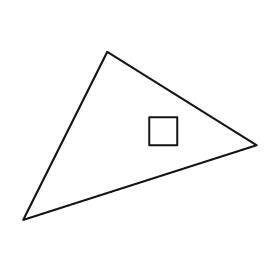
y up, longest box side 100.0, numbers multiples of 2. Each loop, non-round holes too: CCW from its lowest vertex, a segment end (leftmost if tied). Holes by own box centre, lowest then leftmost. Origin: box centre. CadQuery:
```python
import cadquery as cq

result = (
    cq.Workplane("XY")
    .moveTo(-50.0, -36.0)
    .lineTo(50.0, -4.0)
    .lineTo(-14.0, 36.0)
    .close()
    .moveTo(4.0, -4.0)
    .lineTo(16.0, -4.0)
    .lineTo(16.0, 8.0)
    .lineTo(4.0, 8.0)
    .close()
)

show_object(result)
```